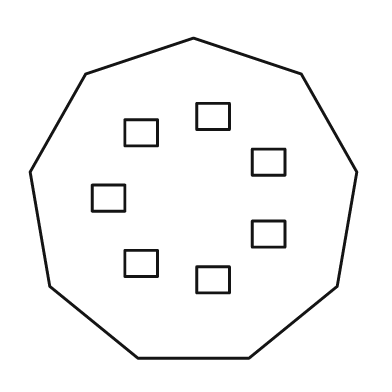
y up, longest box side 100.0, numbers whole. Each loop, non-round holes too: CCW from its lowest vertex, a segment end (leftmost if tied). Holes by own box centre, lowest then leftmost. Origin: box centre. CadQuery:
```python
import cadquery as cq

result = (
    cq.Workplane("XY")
    .moveTo(-17.0, -49.0)
    .lineTo(17.0, -49.0)
    .lineTo(44.0, -27.0)
    .lineTo(50.0, 8.0)
    .lineTo(33.0, 38.0)
    .lineTo(0.0, 49.0)
    .lineTo(-33.0, 38.0)
    .lineTo(-50.0, 8.0)
    .lineTo(-44.0, -27.0)
    .close()
    .moveTo(1.0, -29.0)
    .lineTo(11.0, -29.0)
    .lineTo(11.0, -21.0)
    .lineTo(1.0, -21.0)
    .close()
    .moveTo(-21.0, -24.0)
    .lineTo(-11.0, -24.0)
    .lineTo(-11.0, -16.0)
    .lineTo(-21.0, -16.0)
    .close()
    .moveTo(18.0, -15.0)
    .lineTo(28.0, -15.0)
    .lineTo(28.0, -7.0)
    .lineTo(18.0, -7.0)
    .close()
    .moveTo(-31.0, -4.0)
    .lineTo(-21.0, -4.0)
    .lineTo(-21.0, 4.0)
    .lineTo(-31.0, 4.0)
    .close()
    .moveTo(18.0, 7.0)
    .lineTo(28.0, 7.0)
    .lineTo(28.0, 15.0)
    .lineTo(18.0, 15.0)
    .close()
    .moveTo(-21.0, 16.0)
    .lineTo(-11.0, 16.0)
    .lineTo(-11.0, 24.0)
    .lineTo(-21.0, 24.0)
    .close()
    .moveTo(1.0, 21.0)
    .lineTo(11.0, 21.0)
    .lineTo(11.0, 29.0)
    .lineTo(1.0, 29.0)
    .close()
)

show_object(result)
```